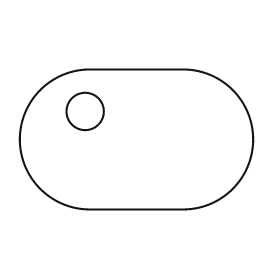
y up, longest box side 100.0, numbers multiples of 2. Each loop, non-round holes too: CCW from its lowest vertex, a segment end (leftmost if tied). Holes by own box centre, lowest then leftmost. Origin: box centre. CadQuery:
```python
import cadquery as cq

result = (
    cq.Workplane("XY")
    .moveTo(-20.0, -30.0)
    .lineTo(20.0, -30.0)
    .threePointArc((50.0, 0.0), (20.0, 30.0))
    .lineTo(-20.0, 30.0)
    .threePointArc((-50.0, 0.0), (-20.0, -30.0))
    .close()
    .moveTo(-22.0, 12.0)
    .circle(8.0)
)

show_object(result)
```